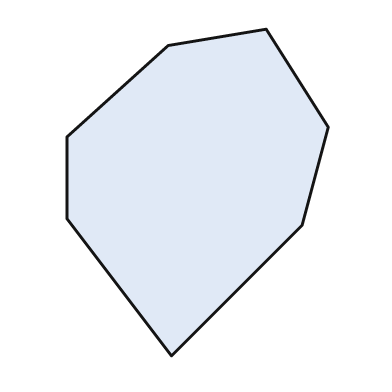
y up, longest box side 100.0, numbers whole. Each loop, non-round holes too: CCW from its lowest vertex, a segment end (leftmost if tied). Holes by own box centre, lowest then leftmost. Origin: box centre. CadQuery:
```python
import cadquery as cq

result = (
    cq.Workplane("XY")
    .moveTo(-8.0, -50.0)
    .lineTo(32.0, -10.0)
    .lineTo(40.0, 20.0)
    .lineTo(21.0, 50.0)
    .lineTo(-9.0, 45.0)
    .lineTo(-40.0, 17.0)
    .lineTo(-40.0, -8.0)
    .close()
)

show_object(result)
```